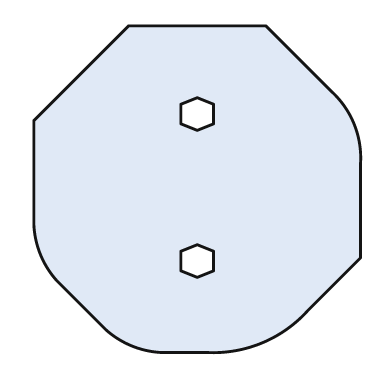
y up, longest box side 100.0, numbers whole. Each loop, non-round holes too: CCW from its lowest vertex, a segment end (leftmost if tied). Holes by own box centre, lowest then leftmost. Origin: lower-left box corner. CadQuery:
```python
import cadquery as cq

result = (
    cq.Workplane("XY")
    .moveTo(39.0, 0.0)
    .lineTo(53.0, 0.0)
    .threePointArc((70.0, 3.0), (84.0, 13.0))
    .lineTo(100.0, 29.0)
    .lineTo(100.0, 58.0)
    .threePointArc((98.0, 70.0), (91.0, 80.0))
    .lineTo(71.0, 100.0)
    .lineTo(29.0, 100.0)
    .lineTo(0.0, 71.0)
    .lineTo(0.0, 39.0)
    .threePointArc((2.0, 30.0), (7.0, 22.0))
    .lineTo(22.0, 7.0)
    .threePointArc((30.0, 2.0), (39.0, 0.0))
    .close()
    .moveTo(50.0, 23.0)
    .lineTo(55.0, 25.0)
    .lineTo(55.0, 31.0)
    .lineTo(50.0, 33.0)
    .lineTo(45.0, 31.0)
    .lineTo(45.0, 25.0)
    .close()
    .moveTo(50.0, 68.0)
    .lineTo(55.0, 70.0)
    .lineTo(55.0, 76.0)
    .lineTo(50.0, 78.0)
    .lineTo(45.0, 76.0)
    .lineTo(45.0, 70.0)
    .close()
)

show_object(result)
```